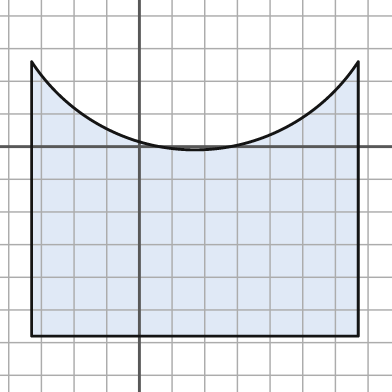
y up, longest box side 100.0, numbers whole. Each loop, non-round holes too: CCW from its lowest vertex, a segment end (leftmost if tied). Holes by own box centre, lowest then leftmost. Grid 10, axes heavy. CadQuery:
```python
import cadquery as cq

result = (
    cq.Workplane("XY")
    .moveTo(-33.0, -58.0)
    .lineTo(67.0, -58.0)
    .lineTo(67.0, 26.0)
    .threePointArc((17.0, -1.0), (-33.0, 26.0))
    .close()
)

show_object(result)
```